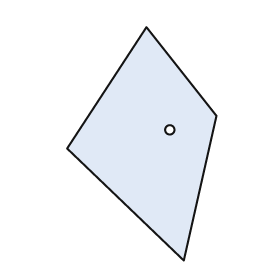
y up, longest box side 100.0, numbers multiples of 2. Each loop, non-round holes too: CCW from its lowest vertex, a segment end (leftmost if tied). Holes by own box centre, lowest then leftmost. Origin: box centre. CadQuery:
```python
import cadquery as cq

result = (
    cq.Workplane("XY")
    .moveTo(18.0, -50.0)
    .lineTo(32.0, 12.0)
    .lineTo(2.0, 50.0)
    .lineTo(-32.0, -2.0)
    .close()
    .moveTo(12.0, 6.0)
    .circle(2.0)
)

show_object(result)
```